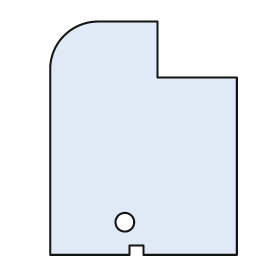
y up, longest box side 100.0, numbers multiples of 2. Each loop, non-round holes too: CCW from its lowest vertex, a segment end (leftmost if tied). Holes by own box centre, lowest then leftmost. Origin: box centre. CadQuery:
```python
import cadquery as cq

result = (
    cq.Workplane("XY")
    .moveTo(-40.0, -50.0)
    .lineTo(-6.0, -50.0)
    .lineTo(-6.0, -46.0)
    .lineTo(0.0, -46.0)
    .lineTo(0.0, -50.0)
    .lineTo(40.0, -50.0)
    .lineTo(40.0, 26.0)
    .lineTo(6.0, 26.0)
    .lineTo(6.0, 50.0)
    .lineTo(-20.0, 50.0)
    .threePointArc((-34.0, 44.0), (-40.0, 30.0))
    .close()
    .moveTo(-8.0, -36.0)
    .circle(4.0)
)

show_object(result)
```